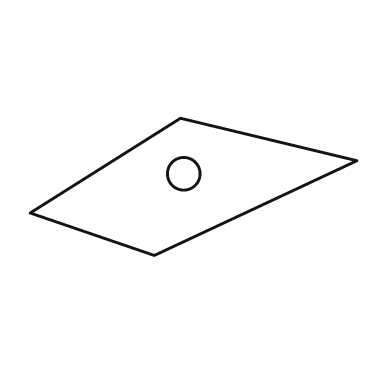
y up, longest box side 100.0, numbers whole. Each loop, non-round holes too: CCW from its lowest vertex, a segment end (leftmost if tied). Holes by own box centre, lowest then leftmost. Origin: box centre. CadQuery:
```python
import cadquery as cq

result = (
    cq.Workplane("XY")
    .moveTo(-12.0, -21.0)
    .lineTo(50.0, 8.0)
    .lineTo(-4.0, 21.0)
    .lineTo(-50.0, -8.0)
    .close()
    .moveTo(-3.0, 4.0)
    .circle(5.0)
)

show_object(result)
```